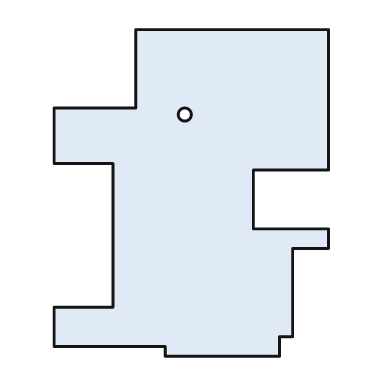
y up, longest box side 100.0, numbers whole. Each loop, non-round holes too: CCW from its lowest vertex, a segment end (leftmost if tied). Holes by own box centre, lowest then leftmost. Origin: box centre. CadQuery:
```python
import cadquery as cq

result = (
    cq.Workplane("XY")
    .moveTo(-8.0, -50.0)
    .lineTo(27.0, -50.0)
    .lineTo(27.0, -44.0)
    .lineTo(31.0, -44.0)
    .lineTo(31.0, -17.0)
    .lineTo(42.0, -17.0)
    .lineTo(42.0, -11.0)
    .lineTo(19.0, -11.0)
    .lineTo(19.0, 7.0)
    .lineTo(42.0, 7.0)
    .lineTo(42.0, 50.0)
    .lineTo(-17.0, 50.0)
    .lineTo(-17.0, 26.0)
    .lineTo(-42.0, 26.0)
    .lineTo(-42.0, 9.0)
    .lineTo(-24.0, 9.0)
    .lineTo(-24.0, -35.0)
    .lineTo(-42.0, -35.0)
    .lineTo(-42.0, -47.0)
    .lineTo(-8.0, -47.0)
    .close()
    .moveTo(-2.0, 24.0)
    .circle(2.0)
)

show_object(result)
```